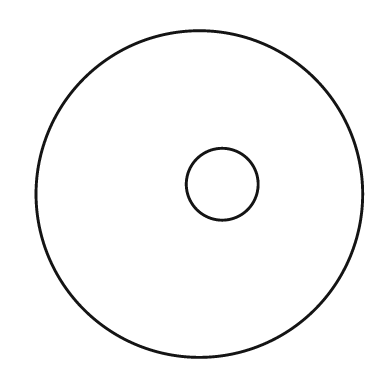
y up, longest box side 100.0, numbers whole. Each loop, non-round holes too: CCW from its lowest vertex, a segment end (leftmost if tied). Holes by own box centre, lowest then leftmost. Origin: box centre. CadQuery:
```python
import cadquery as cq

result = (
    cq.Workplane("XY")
    .moveTo(0.0, 0.0)
    .circle(50.0)
    .moveTo(7.0, 3.0)
    .circle(11.0)
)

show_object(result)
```